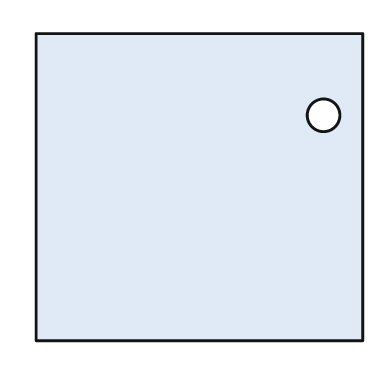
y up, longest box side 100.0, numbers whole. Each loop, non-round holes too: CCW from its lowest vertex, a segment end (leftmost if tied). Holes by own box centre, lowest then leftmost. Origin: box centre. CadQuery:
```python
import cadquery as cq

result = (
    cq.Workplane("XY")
    .moveTo(-50.0, -47.0)
    .lineTo(50.0, -47.0)
    .lineTo(50.0, 47.0)
    .lineTo(-50.0, 47.0)
    .close()
    .moveTo(38.0, 22.0)
    .circle(5.0)
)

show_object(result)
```